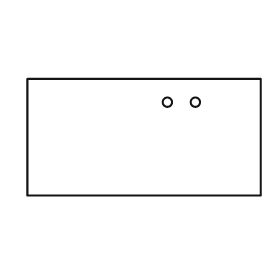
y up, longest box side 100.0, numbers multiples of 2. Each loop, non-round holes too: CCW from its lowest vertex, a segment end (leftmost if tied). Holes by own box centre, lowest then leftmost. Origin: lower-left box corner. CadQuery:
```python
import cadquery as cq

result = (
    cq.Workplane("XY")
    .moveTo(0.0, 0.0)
    .lineTo(100.0, 0.0)
    .lineTo(100.0, 50.0)
    .lineTo(0.0, 50.0)
    .close()
    .moveTo(60.0, 40.0)
    .circle(2.0)
    .moveTo(72.0, 40.0)
    .circle(2.0)
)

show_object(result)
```